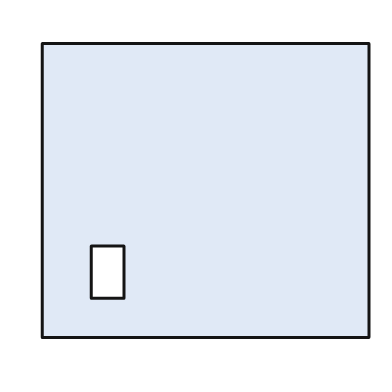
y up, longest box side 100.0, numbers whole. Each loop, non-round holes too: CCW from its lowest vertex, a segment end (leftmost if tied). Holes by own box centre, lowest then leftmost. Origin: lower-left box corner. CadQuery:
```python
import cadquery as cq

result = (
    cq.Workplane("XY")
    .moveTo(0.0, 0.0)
    .lineTo(100.0, 0.0)
    .lineTo(100.0, 90.0)
    .lineTo(0.0, 90.0)
    .close()
    .moveTo(15.0, 12.0)
    .lineTo(25.0, 12.0)
    .lineTo(25.0, 28.0)
    .lineTo(15.0, 28.0)
    .close()
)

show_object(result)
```